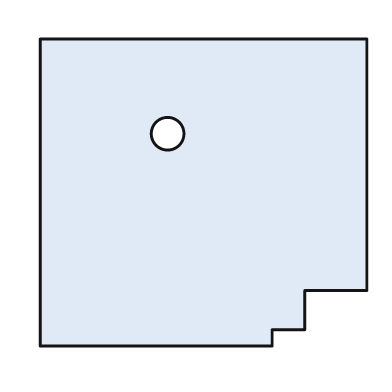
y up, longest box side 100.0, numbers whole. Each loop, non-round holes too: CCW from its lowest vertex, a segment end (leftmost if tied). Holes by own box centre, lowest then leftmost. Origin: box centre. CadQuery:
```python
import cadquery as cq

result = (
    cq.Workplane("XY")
    .moveTo(-50.0, -47.0)
    .lineTo(21.0, -47.0)
    .lineTo(21.0, -42.0)
    .lineTo(31.0, -42.0)
    .lineTo(31.0, -30.0)
    .lineTo(50.0, -30.0)
    .lineTo(50.0, 47.0)
    .lineTo(-50.0, 47.0)
    .close()
    .moveTo(-11.0, 18.0)
    .circle(5.0)
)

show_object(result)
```